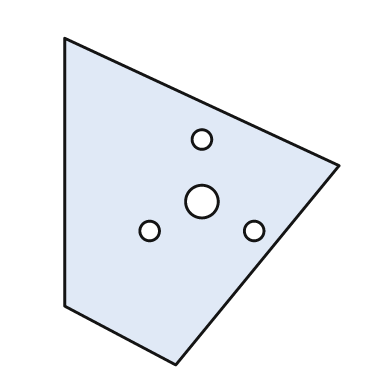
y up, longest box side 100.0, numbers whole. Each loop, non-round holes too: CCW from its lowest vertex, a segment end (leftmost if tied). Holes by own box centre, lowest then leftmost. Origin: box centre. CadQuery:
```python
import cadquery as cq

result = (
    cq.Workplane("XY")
    .moveTo(-8.0, -50.0)
    .lineTo(42.0, 11.0)
    .lineTo(-42.0, 50.0)
    .lineTo(-42.0, -32.0)
    .close()
    .moveTo(-16.0, -9.0)
    .circle(3.0)
    .moveTo(16.0, -9.0)
    .circle(3.0)
    .moveTo(0.0, 0.0)
    .circle(5.0)
    .moveTo(0.0, 19.0)
    .circle(3.0)
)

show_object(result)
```